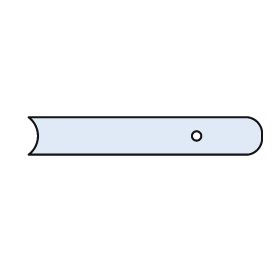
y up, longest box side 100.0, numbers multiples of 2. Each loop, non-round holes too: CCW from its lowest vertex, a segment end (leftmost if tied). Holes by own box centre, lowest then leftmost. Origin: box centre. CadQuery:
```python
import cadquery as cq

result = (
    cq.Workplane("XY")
    .moveTo(-50.0, -8.0)
    .lineTo(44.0, -8.0)
    .threePointArc((48.0, -6.0), (50.0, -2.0))
    .lineTo(50.0, 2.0)
    .threePointArc((48.0, 6.0), (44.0, 8.0))
    .lineTo(-50.0, 8.0)
    .threePointArc((-46.0, 0.0), (-50.0, -8.0))
    .close()
    .moveTo(22.0, 0.0)
    .circle(2.0)
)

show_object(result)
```